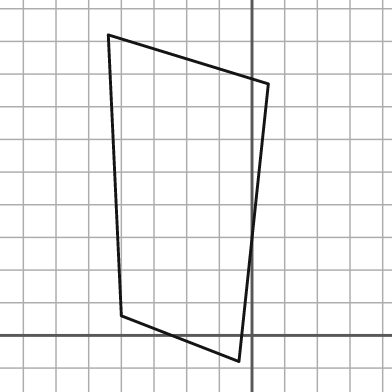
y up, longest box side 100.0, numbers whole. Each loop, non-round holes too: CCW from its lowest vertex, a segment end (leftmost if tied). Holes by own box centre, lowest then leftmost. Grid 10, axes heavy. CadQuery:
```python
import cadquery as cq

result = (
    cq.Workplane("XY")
    .moveTo(-4.0, -8.0)
    .lineTo(5.0, 77.0)
    .lineTo(-44.0, 92.0)
    .lineTo(-40.0, 6.0)
    .close()
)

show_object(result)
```